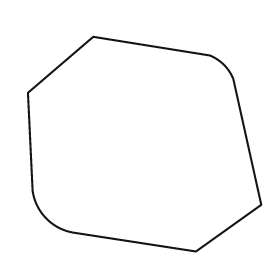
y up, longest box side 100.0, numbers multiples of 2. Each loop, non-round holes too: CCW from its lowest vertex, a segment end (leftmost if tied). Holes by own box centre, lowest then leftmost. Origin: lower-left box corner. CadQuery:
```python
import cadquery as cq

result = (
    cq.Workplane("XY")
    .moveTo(72.0, 0.0)
    .lineTo(100.0, 20.0)
    .lineTo(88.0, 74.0)
    .threePointArc((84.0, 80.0), (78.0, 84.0))
    .lineTo(28.0, 92.0)
    .lineTo(0.0, 68.0)
    .lineTo(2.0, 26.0)
    .threePointArc((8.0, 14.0), (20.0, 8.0))
    .close()
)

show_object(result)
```